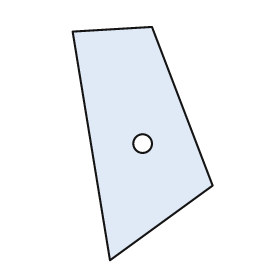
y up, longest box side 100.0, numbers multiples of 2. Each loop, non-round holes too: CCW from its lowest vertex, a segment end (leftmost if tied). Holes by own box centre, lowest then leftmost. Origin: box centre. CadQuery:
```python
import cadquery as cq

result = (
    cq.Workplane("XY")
    .moveTo(-14.0, -50.0)
    .lineTo(30.0, -18.0)
    .lineTo(4.0, 50.0)
    .lineTo(-30.0, 48.0)
    .close()
    .moveTo(0.0, 0.0)
    .circle(4.0)
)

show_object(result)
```